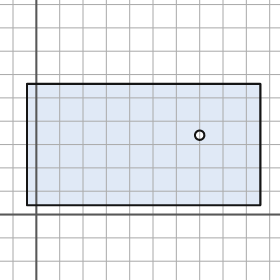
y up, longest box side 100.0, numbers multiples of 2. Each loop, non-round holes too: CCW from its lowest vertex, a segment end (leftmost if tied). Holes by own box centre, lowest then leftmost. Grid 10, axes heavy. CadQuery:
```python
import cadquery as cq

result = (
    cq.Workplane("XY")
    .moveTo(-4.0, 4.0)
    .lineTo(96.0, 4.0)
    .lineTo(96.0, 56.0)
    .lineTo(-4.0, 56.0)
    .close()
    .moveTo(70.0, 34.0)
    .circle(2.0)
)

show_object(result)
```